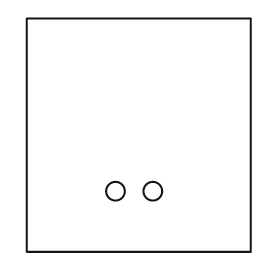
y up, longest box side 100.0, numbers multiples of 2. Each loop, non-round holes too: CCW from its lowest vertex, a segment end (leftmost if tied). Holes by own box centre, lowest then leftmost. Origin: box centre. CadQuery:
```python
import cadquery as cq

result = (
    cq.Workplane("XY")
    .moveTo(-48.0, -50.0)
    .lineTo(48.0, -50.0)
    .lineTo(48.0, 50.0)
    .lineTo(-48.0, 50.0)
    .close()
    .moveTo(-10.0, -24.0)
    .circle(4.0)
    .moveTo(6.0, -24.0)
    .circle(4.0)
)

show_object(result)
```